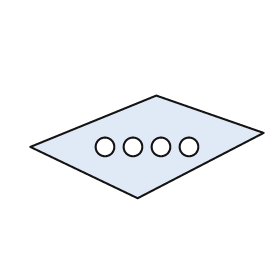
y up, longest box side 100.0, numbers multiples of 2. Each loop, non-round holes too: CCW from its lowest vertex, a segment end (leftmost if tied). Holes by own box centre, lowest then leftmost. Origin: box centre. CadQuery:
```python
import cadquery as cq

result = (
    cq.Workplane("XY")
    .moveTo(-4.0, -22.0)
    .lineTo(50.0, 6.0)
    .lineTo(4.0, 22.0)
    .lineTo(-50.0, 0.0)
    .close()
    .moveTo(-18.0, 0.0)
    .circle(4.0)
    .moveTo(-6.0, 0.0)
    .circle(4.0)
    .moveTo(6.0, 0.0)
    .circle(4.0)
    .moveTo(18.0, 0.0)
    .circle(4.0)
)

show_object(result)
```